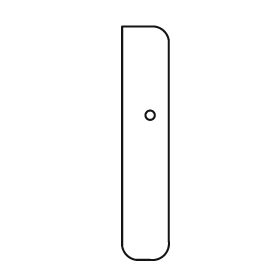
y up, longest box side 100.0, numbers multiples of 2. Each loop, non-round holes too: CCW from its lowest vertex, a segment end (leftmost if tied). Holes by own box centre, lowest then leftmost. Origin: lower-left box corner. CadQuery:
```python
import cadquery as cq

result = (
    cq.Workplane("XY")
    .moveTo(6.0, 0.0)
    .lineTo(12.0, 0.0)
    .threePointArc((18.0, 2.0), (20.0, 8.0))
    .lineTo(20.0, 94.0)
    .threePointArc((18.0, 98.0), (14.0, 100.0))
    .lineTo(0.0, 100.0)
    .lineTo(0.0, 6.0)
    .threePointArc((2.0, 2.0), (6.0, 0.0))
    .close()
    .moveTo(12.0, 62.0)
    .circle(2.0)
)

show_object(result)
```